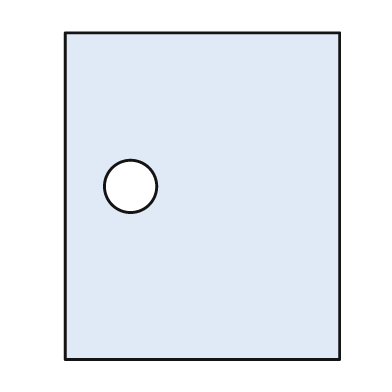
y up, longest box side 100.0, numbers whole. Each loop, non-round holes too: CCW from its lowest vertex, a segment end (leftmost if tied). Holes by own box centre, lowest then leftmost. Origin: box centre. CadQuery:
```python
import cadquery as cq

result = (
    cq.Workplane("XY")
    .moveTo(-42.0, -50.0)
    .lineTo(42.0, -50.0)
    .lineTo(42.0, 50.0)
    .lineTo(-42.0, 50.0)
    .close()
    .moveTo(-22.0, 3.0)
    .circle(8.0)
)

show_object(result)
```